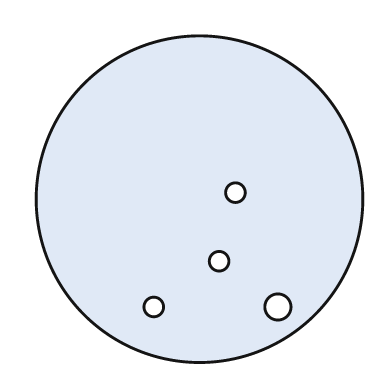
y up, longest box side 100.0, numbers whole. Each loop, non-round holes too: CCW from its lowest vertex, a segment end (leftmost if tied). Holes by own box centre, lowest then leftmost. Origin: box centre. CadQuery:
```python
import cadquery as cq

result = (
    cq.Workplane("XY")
    .moveTo(0.0, 0.0)
    .circle(50.0)
    .moveTo(-14.0, -33.0)
    .circle(3.0)
    .moveTo(24.0, -33.0)
    .circle(4.0)
    .moveTo(6.0, -19.0)
    .circle(3.0)
    .moveTo(11.0, 2.0)
    .circle(3.0)
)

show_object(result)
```